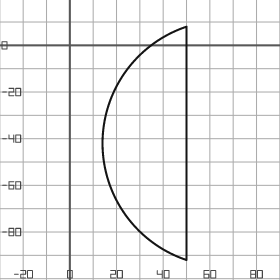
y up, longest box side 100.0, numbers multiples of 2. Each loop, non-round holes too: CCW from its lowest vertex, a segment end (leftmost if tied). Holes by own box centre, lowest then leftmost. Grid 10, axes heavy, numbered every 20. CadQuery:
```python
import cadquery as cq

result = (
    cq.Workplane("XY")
    .moveTo(50.0, -92.0)
    .lineTo(50.0, 8.0)
    .threePointArc((14.0, -42.0), (50.0, -92.0))
    .close()
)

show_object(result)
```